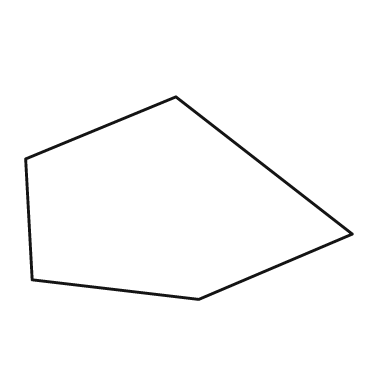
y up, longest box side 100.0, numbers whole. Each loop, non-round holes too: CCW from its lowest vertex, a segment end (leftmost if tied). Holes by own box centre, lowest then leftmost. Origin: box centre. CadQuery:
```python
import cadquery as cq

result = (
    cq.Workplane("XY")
    .moveTo(3.0, -31.0)
    .lineTo(50.0, -11.0)
    .lineTo(-4.0, 31.0)
    .lineTo(-50.0, 12.0)
    .lineTo(-48.0, -25.0)
    .close()
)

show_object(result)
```